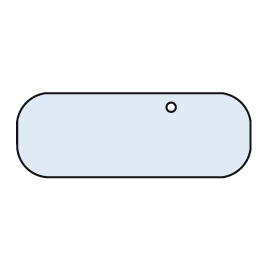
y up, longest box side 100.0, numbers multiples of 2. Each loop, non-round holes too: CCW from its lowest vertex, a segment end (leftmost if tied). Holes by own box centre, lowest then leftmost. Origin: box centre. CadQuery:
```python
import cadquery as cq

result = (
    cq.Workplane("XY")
    .moveTo(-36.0, -18.0)
    .lineTo(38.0, -18.0)
    .threePointArc((46.0, -14.0), (50.0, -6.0))
    .lineTo(50.0, 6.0)
    .threePointArc((46.0, 14.0), (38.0, 18.0))
    .lineTo(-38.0, 18.0)
    .threePointArc((-46.0, 14.0), (-50.0, 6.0))
    .lineTo(-50.0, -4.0)
    .threePointArc((-46.0, -14.0), (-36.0, -18.0))
    .close()
    .moveTo(16.0, 12.0)
    .circle(2.0)
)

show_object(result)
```